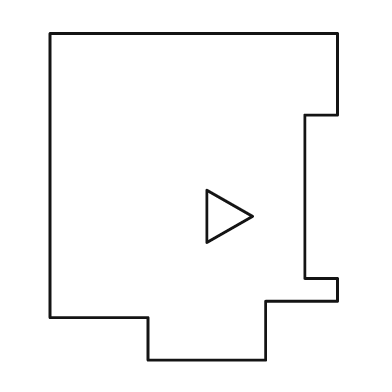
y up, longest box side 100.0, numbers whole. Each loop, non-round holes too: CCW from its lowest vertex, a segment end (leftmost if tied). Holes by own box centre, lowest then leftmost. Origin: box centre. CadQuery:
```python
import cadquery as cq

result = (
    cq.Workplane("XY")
    .moveTo(-14.0, -50.0)
    .lineTo(22.0, -50.0)
    .lineTo(22.0, -32.0)
    .lineTo(44.0, -32.0)
    .lineTo(44.0, -25.0)
    .lineTo(34.0, -25.0)
    .lineTo(34.0, 25.0)
    .lineTo(44.0, 25.0)
    .lineTo(44.0, 50.0)
    .lineTo(-44.0, 50.0)
    .lineTo(-44.0, -37.0)
    .lineTo(-14.0, -37.0)
    .close()
    .moveTo(4.0, -14.0)
    .lineTo(18.0, -6.0)
    .lineTo(4.0, 2.0)
    .close()
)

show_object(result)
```